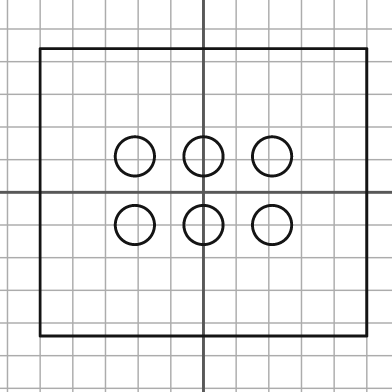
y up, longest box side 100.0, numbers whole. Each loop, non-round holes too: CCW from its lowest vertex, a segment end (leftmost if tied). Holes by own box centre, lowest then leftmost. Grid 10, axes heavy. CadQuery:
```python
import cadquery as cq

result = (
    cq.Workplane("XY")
    .moveTo(-50.0, -44.0)
    .lineTo(50.0, -44.0)
    .lineTo(50.0, 44.0)
    .lineTo(-50.0, 44.0)
    .close()
    .moveTo(-21.0, -10.0)
    .circle(6.0)
    .moveTo(0.0, -10.0)
    .circle(6.0)
    .moveTo(21.0, -10.0)
    .circle(6.0)
    .moveTo(-21.0, 11.0)
    .circle(6.0)
    .moveTo(0.0, 11.0)
    .circle(6.0)
    .moveTo(21.0, 11.0)
    .circle(6.0)
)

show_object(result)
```